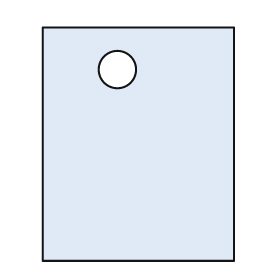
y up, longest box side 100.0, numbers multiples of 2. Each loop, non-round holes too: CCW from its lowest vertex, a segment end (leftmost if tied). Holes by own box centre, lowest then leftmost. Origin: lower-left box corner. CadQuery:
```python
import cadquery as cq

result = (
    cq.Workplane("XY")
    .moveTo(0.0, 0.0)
    .lineTo(82.0, 0.0)
    .lineTo(82.0, 100.0)
    .lineTo(0.0, 100.0)
    .close()
    .moveTo(32.0, 82.0)
    .circle(8.0)
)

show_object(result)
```